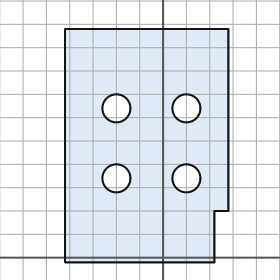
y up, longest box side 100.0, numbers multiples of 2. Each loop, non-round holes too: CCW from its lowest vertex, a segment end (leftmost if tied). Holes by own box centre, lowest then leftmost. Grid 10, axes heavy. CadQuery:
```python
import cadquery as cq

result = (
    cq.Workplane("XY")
    .moveTo(-42.0, -2.0)
    .lineTo(22.0, -2.0)
    .lineTo(22.0, 20.0)
    .lineTo(28.0, 20.0)
    .lineTo(28.0, 98.0)
    .lineTo(-42.0, 98.0)
    .close()
    .moveTo(-20.0, 34.0)
    .circle(6.0)
    .moveTo(10.0, 34.0)
    .circle(6.0)
    .moveTo(-20.0, 64.0)
    .circle(6.0)
    .moveTo(10.0, 64.0)
    .circle(6.0)
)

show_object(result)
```